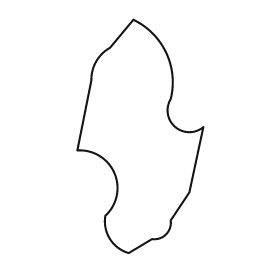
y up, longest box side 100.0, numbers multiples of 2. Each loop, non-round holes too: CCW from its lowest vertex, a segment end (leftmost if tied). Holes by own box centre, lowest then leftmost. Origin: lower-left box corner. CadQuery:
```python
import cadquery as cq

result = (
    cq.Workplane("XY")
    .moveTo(22.0, 0.0)
    .lineTo(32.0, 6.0)
    .threePointArc((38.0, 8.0), (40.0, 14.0))
    .lineTo(48.0, 26.0)
    .lineTo(54.0, 54.0)
    .threePointArc((42.0, 54.0), (40.0, 66.0))
    .threePointArc((38.0, 86.0), (24.0, 100.0))
    .lineTo(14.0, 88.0)
    .threePointArc((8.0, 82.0), (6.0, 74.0))
    .lineTo(0.0, 44.0)
    .threePointArc((16.0, 34.0), (12.0, 16.0))
    .threePointArc((14.0, 6.0), (22.0, 0.0))
    .close()
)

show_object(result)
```